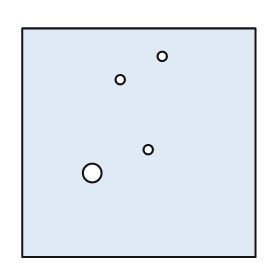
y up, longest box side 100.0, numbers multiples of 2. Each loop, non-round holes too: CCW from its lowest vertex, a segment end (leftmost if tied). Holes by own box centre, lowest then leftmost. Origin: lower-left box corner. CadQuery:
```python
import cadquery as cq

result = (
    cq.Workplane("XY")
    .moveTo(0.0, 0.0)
    .lineTo(100.0, 0.0)
    .lineTo(100.0, 98.0)
    .lineTo(0.0, 98.0)
    .close()
    .moveTo(30.0, 36.0)
    .circle(4.0)
    .moveTo(54.0, 46.0)
    .circle(2.0)
    .moveTo(42.0, 76.0)
    .circle(2.0)
    .moveTo(60.0, 86.0)
    .circle(2.0)
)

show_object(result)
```